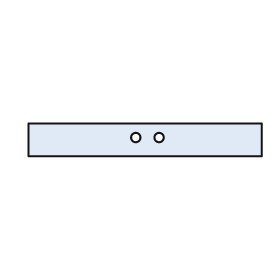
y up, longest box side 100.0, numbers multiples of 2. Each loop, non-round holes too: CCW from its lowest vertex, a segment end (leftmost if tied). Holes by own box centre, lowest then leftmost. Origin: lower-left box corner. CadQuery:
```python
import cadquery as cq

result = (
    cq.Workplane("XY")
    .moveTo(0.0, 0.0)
    .lineTo(100.0, 0.0)
    .lineTo(100.0, 14.0)
    .lineTo(0.0, 14.0)
    .close()
    .moveTo(46.0, 8.0)
    .circle(2.0)
    .moveTo(56.0, 8.0)
    .circle(2.0)
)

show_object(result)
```